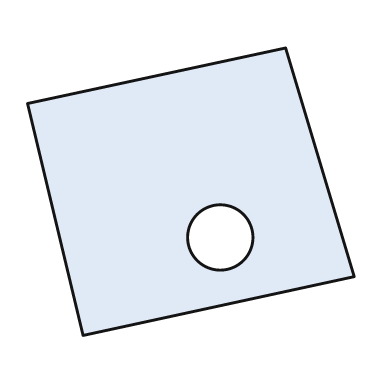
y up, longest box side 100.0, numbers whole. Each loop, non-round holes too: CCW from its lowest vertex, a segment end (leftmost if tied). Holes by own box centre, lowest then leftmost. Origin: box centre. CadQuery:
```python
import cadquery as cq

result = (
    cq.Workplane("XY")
    .moveTo(-33.0, -44.0)
    .lineTo(50.0, -26.0)
    .lineTo(29.0, 44.0)
    .lineTo(-50.0, 27.0)
    .close()
    .moveTo(9.0, -14.0)
    .circle(10.0)
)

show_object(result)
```